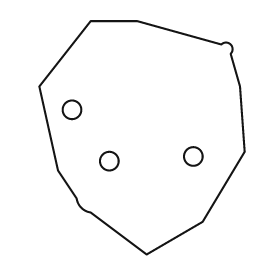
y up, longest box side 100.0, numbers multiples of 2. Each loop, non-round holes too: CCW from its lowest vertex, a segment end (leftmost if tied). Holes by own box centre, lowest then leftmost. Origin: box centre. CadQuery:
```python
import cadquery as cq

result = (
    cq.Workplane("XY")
    .moveTo(2.0, -50.0)
    .lineTo(26.0, -36.0)
    .lineTo(44.0, -6.0)
    .lineTo(42.0, 22.0)
    .lineTo(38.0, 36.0)
    .threePointArc((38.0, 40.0), (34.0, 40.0))
    .lineTo(-2.0, 50.0)
    .lineTo(-22.0, 50.0)
    .lineTo(-44.0, 22.0)
    .lineTo(-36.0, -14.0)
    .lineTo(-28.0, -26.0)
    .threePointArc((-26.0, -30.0), (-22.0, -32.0))
    .close()
    .moveTo(-14.0, -10.0)
    .circle(4.0)
    .moveTo(22.0, -8.0)
    .circle(4.0)
    .moveTo(-30.0, 12.0)
    .circle(4.0)
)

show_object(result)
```